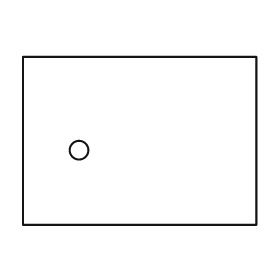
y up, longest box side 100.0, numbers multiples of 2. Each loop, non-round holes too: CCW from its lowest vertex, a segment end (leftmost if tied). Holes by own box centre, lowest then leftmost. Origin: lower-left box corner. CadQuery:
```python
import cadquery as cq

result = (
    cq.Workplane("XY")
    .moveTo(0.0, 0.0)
    .lineTo(100.0, 0.0)
    .lineTo(100.0, 72.0)
    .lineTo(0.0, 72.0)
    .close()
    .moveTo(24.0, 32.0)
    .circle(4.0)
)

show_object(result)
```